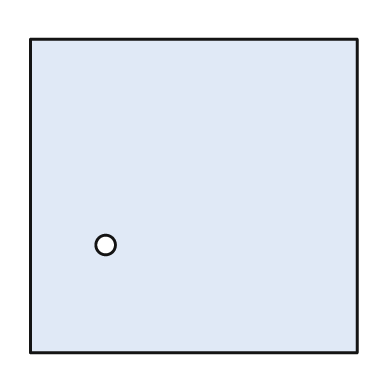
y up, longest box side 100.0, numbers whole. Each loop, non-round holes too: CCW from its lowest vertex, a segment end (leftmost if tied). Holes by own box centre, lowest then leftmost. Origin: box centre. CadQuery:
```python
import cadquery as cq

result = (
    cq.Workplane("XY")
    .moveTo(-50.0, -48.0)
    .lineTo(50.0, -48.0)
    .lineTo(50.0, 48.0)
    .lineTo(-50.0, 48.0)
    .close()
    .moveTo(-27.0, -15.0)
    .circle(3.0)
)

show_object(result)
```